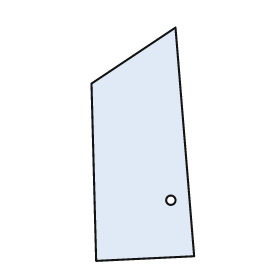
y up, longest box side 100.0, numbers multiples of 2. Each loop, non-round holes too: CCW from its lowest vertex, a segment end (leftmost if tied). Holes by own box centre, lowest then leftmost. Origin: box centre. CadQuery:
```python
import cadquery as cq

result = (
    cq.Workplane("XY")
    .moveTo(-20.0, -50.0)
    .lineTo(22.0, -48.0)
    .lineTo(14.0, 50.0)
    .lineTo(-22.0, 26.0)
    .close()
    .moveTo(12.0, -24.0)
    .circle(2.0)
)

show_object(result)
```